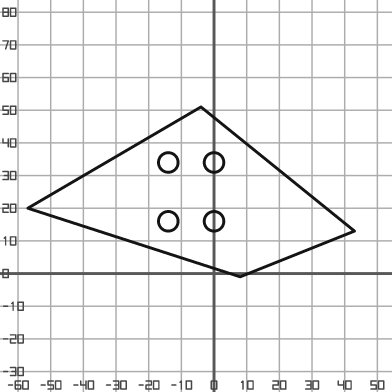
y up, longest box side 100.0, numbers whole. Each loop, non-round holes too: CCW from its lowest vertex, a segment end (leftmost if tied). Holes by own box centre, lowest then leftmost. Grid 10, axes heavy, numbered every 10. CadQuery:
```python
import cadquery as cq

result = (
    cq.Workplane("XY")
    .moveTo(8.0, -1.0)
    .lineTo(43.0, 13.0)
    .lineTo(-4.0, 51.0)
    .lineTo(-57.0, 20.0)
    .close()
    .moveTo(-14.0, 16.0)
    .circle(3.0)
    .moveTo(0.0, 16.0)
    .circle(3.0)
    .moveTo(-14.0, 34.0)
    .circle(3.0)
    .moveTo(0.0, 34.0)
    .circle(3.0)
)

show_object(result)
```